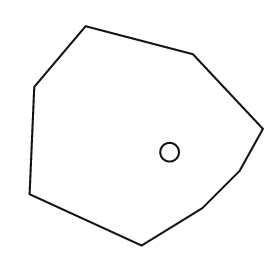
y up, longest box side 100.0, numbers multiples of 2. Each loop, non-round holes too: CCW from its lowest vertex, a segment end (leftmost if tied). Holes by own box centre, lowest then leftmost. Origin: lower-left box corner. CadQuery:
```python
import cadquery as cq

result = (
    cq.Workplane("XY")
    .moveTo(48.0, 0.0)
    .lineTo(74.0, 16.0)
    .lineTo(90.0, 32.0)
    .lineTo(100.0, 50.0)
    .lineTo(70.0, 82.0)
    .lineTo(24.0, 94.0)
    .lineTo(2.0, 68.0)
    .lineTo(0.0, 22.0)
    .close()
    .moveTo(60.0, 40.0)
    .circle(4.0)
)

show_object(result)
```